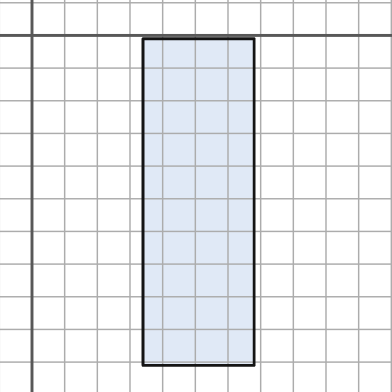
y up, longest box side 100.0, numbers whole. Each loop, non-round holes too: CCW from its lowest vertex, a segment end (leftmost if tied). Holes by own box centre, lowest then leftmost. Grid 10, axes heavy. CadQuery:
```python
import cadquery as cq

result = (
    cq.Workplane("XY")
    .moveTo(34.0, -101.0)
    .lineTo(68.0, -101.0)
    .lineTo(68.0, -1.0)
    .lineTo(34.0, -1.0)
    .close()
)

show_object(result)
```